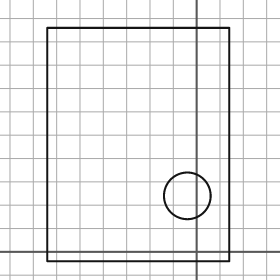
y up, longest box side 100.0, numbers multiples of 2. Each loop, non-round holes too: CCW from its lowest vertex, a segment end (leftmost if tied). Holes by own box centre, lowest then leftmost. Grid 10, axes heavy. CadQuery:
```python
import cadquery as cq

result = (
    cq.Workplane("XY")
    .moveTo(-64.0, -4.0)
    .lineTo(14.0, -4.0)
    .lineTo(14.0, 96.0)
    .lineTo(-64.0, 96.0)
    .close()
    .moveTo(-4.0, 24.0)
    .circle(10.0)
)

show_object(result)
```